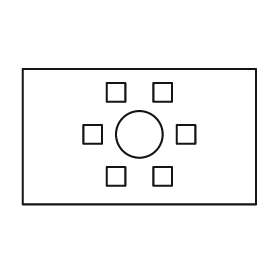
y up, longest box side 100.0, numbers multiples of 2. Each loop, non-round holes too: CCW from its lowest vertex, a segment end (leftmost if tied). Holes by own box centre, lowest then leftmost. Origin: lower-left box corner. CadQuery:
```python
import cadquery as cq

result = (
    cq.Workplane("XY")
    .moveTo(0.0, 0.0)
    .lineTo(100.0, 0.0)
    .lineTo(100.0, 58.0)
    .lineTo(0.0, 58.0)
    .close()
    .moveTo(36.0, 8.0)
    .lineTo(44.0, 8.0)
    .lineTo(44.0, 16.0)
    .lineTo(36.0, 16.0)
    .close()
    .moveTo(56.0, 8.0)
    .lineTo(64.0, 8.0)
    .lineTo(64.0, 16.0)
    .lineTo(56.0, 16.0)
    .close()
    .moveTo(26.0, 26.0)
    .lineTo(34.0, 26.0)
    .lineTo(34.0, 34.0)
    .lineTo(26.0, 34.0)
    .close()
    .moveTo(50.0, 30.0)
    .circle(10.0)
    .moveTo(66.0, 26.0)
    .lineTo(74.0, 26.0)
    .lineTo(74.0, 34.0)
    .lineTo(66.0, 34.0)
    .close()
    .moveTo(36.0, 44.0)
    .lineTo(44.0, 44.0)
    .lineTo(44.0, 52.0)
    .lineTo(36.0, 52.0)
    .close()
    .moveTo(56.0, 44.0)
    .lineTo(64.0, 44.0)
    .lineTo(64.0, 52.0)
    .lineTo(56.0, 52.0)
    .close()
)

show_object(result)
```